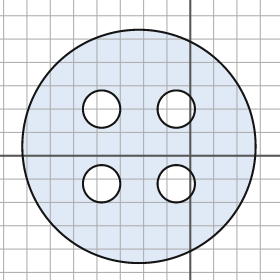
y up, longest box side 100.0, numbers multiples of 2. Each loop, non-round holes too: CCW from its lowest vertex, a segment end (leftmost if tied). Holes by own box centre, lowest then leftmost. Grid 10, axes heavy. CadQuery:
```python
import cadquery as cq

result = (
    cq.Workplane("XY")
    .moveTo(-22.0, 4.0)
    .circle(50.0)
    .moveTo(-38.0, -12.0)
    .circle(8.0)
    .moveTo(-6.0, -12.0)
    .circle(8.0)
    .moveTo(-38.0, 20.0)
    .circle(8.0)
    .moveTo(-6.0, 20.0)
    .circle(8.0)
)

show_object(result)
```